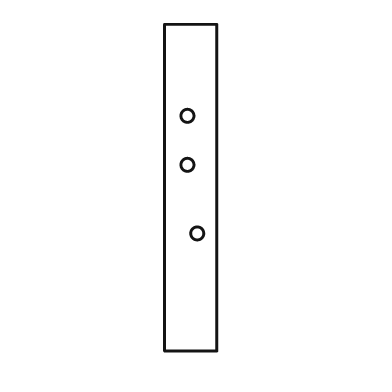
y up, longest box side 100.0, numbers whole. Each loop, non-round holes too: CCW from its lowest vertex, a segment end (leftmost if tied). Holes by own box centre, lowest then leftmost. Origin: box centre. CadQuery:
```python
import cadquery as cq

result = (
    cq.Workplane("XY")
    .moveTo(-8.0, -50.0)
    .lineTo(8.0, -50.0)
    .lineTo(8.0, 50.0)
    .lineTo(-8.0, 50.0)
    .close()
    .moveTo(2.0, -14.0)
    .circle(2.0)
    .moveTo(-1.0, 7.0)
    .circle(2.0)
    .moveTo(-1.0, 22.0)
    .circle(2.0)
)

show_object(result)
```